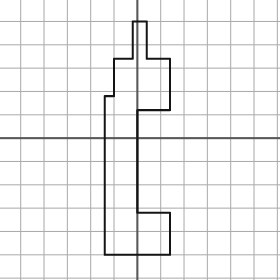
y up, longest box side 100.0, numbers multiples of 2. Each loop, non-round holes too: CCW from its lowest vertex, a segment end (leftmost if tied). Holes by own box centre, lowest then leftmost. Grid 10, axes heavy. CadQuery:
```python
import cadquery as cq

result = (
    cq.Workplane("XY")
    .moveTo(-14.0, -50.0)
    .lineTo(14.0, -50.0)
    .lineTo(14.0, -32.0)
    .lineTo(0.0, -32.0)
    .lineTo(0.0, 12.0)
    .lineTo(14.0, 12.0)
    .lineTo(14.0, 34.0)
    .lineTo(4.0, 34.0)
    .lineTo(4.0, 50.0)
    .lineTo(-2.0, 50.0)
    .lineTo(-2.0, 34.0)
    .lineTo(-10.0, 34.0)
    .lineTo(-10.0, 18.0)
    .lineTo(-14.0, 18.0)
    .close()
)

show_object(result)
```